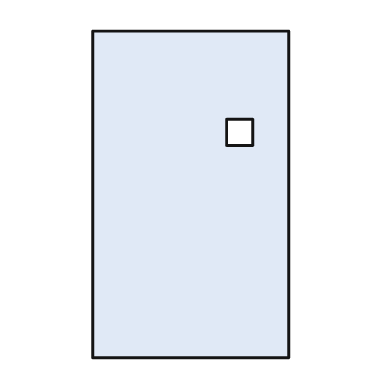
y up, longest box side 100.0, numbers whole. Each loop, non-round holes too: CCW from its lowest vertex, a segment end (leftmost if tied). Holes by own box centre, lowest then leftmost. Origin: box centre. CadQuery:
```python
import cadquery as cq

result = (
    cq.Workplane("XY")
    .moveTo(-30.0, -50.0)
    .lineTo(30.0, -50.0)
    .lineTo(30.0, 50.0)
    .lineTo(-30.0, 50.0)
    .close()
    .moveTo(11.0, 15.0)
    .lineTo(19.0, 15.0)
    .lineTo(19.0, 23.0)
    .lineTo(11.0, 23.0)
    .close()
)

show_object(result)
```